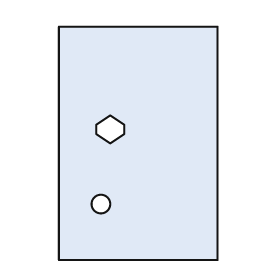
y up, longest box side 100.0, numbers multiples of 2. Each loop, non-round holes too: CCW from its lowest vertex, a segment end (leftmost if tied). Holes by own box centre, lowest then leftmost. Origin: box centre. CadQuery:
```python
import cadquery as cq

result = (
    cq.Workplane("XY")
    .moveTo(-34.0, -50.0)
    .lineTo(34.0, -50.0)
    .lineTo(34.0, 50.0)
    .lineTo(-34.0, 50.0)
    .close()
    .moveTo(-16.0, -26.0)
    .circle(4.0)
    .moveTo(-12.0, 0.0)
    .lineTo(-6.0, 4.0)
    .lineTo(-6.0, 8.0)
    .lineTo(-12.0, 12.0)
    .lineTo(-18.0, 8.0)
    .lineTo(-18.0, 4.0)
    .close()
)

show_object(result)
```